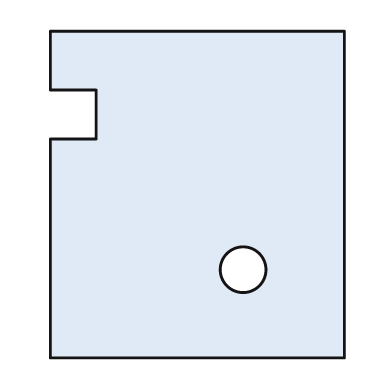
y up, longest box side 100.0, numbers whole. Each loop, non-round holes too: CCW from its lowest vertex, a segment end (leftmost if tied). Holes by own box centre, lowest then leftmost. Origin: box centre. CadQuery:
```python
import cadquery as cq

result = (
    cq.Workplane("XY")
    .moveTo(-45.0, -50.0)
    .lineTo(45.0, -50.0)
    .lineTo(45.0, 50.0)
    .lineTo(-45.0, 50.0)
    .lineTo(-45.0, 32.0)
    .lineTo(-31.0, 32.0)
    .lineTo(-31.0, 17.0)
    .lineTo(-45.0, 17.0)
    .close()
    .moveTo(14.0, -23.0)
    .circle(7.0)
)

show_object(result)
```